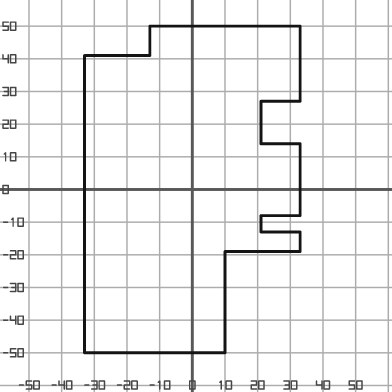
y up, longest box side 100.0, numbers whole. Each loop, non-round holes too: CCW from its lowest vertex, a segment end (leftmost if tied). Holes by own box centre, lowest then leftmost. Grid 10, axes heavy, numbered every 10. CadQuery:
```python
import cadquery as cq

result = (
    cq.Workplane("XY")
    .moveTo(-33.0, -50.0)
    .lineTo(10.0, -50.0)
    .lineTo(10.0, -19.0)
    .lineTo(33.0, -19.0)
    .lineTo(33.0, -13.0)
    .lineTo(21.0, -13.0)
    .lineTo(21.0, -8.0)
    .lineTo(33.0, -8.0)
    .lineTo(33.0, 14.0)
    .lineTo(21.0, 14.0)
    .lineTo(21.0, 27.0)
    .lineTo(33.0, 27.0)
    .lineTo(33.0, 50.0)
    .lineTo(-13.0, 50.0)
    .lineTo(-13.0, 41.0)
    .lineTo(-33.0, 41.0)
    .close()
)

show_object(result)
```